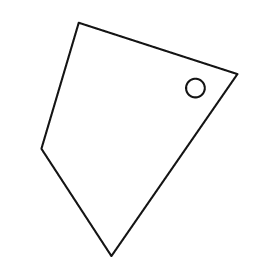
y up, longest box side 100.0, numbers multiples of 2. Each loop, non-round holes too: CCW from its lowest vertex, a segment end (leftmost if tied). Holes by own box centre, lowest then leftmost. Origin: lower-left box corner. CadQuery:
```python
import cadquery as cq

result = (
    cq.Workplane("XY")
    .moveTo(30.0, 0.0)
    .lineTo(84.0, 78.0)
    .lineTo(16.0, 100.0)
    .lineTo(0.0, 46.0)
    .close()
    .moveTo(66.0, 72.0)
    .circle(4.0)
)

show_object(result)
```